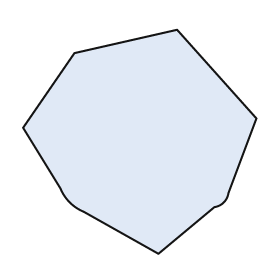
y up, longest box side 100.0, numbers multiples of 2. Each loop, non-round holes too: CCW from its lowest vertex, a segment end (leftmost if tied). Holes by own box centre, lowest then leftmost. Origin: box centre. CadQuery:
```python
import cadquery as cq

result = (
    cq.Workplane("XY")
    .moveTo(8.0, -48.0)
    .lineTo(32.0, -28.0)
    .threePointArc((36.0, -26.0), (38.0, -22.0))
    .lineTo(50.0, 10.0)
    .lineTo(16.0, 48.0)
    .lineTo(-28.0, 38.0)
    .lineTo(-50.0, 6.0)
    .lineTo(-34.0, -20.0)
    .threePointArc((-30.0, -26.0), (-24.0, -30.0))
    .close()
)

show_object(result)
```